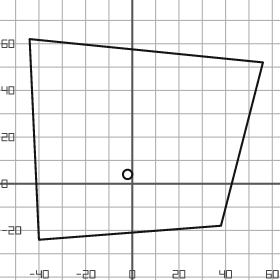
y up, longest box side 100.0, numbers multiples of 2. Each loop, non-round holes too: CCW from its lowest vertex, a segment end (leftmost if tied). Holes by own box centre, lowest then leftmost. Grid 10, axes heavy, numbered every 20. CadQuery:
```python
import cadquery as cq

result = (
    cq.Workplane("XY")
    .moveTo(-40.0, -24.0)
    .lineTo(38.0, -18.0)
    .lineTo(56.0, 52.0)
    .lineTo(-44.0, 62.0)
    .close()
    .moveTo(-2.0, 4.0)
    .circle(2.0)
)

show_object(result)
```